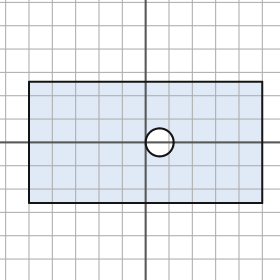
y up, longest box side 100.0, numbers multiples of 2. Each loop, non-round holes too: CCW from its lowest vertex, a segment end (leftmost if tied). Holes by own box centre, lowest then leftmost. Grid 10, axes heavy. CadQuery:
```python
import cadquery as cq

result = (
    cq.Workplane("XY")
    .moveTo(-50.0, -26.0)
    .lineTo(50.0, -26.0)
    .lineTo(50.0, 26.0)
    .lineTo(-50.0, 26.0)
    .close()
    .moveTo(6.0, 0.0)
    .circle(6.0)
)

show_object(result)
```